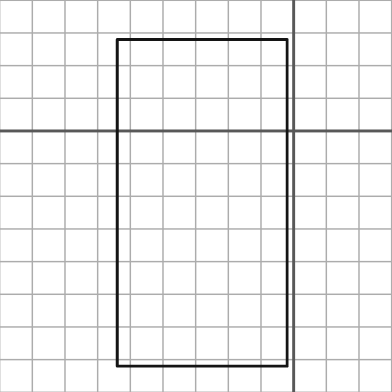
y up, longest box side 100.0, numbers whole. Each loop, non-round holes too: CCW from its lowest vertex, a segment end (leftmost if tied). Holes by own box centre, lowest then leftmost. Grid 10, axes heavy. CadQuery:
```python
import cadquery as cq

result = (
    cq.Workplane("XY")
    .moveTo(-54.0, -72.0)
    .lineTo(-2.0, -72.0)
    .lineTo(-2.0, 28.0)
    .lineTo(-54.0, 28.0)
    .close()
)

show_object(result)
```